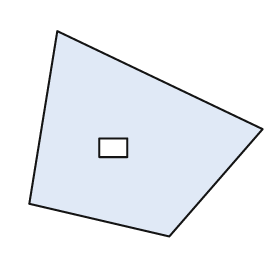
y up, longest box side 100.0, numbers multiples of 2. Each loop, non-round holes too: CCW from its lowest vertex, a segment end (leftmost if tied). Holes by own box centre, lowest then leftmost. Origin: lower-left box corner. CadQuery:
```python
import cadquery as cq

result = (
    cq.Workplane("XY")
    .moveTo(60.0, 0.0)
    .lineTo(100.0, 46.0)
    .lineTo(12.0, 88.0)
    .lineTo(0.0, 14.0)
    .close()
    .moveTo(30.0, 34.0)
    .lineTo(42.0, 34.0)
    .lineTo(42.0, 42.0)
    .lineTo(30.0, 42.0)
    .close()
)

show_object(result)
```